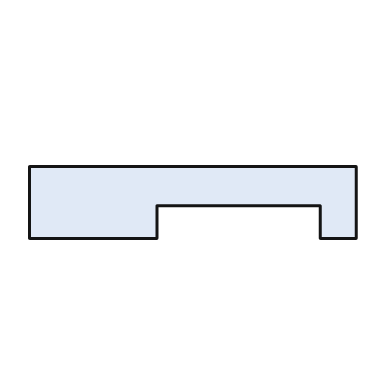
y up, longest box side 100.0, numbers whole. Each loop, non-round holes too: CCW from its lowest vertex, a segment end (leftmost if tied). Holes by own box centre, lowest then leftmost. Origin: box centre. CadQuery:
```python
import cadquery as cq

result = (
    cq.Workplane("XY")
    .moveTo(-50.0, -11.0)
    .lineTo(-11.0, -11.0)
    .lineTo(-11.0, -1.0)
    .lineTo(39.0, -1.0)
    .lineTo(39.0, -11.0)
    .lineTo(50.0, -11.0)
    .lineTo(50.0, 11.0)
    .lineTo(-50.0, 11.0)
    .close()
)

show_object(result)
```